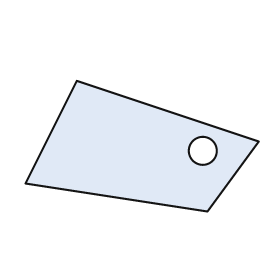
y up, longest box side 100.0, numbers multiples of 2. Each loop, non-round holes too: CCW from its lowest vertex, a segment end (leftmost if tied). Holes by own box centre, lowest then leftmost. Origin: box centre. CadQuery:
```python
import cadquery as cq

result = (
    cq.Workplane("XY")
    .moveTo(28.0, -28.0)
    .lineTo(50.0, 2.0)
    .lineTo(-28.0, 28.0)
    .lineTo(-50.0, -16.0)
    .close()
    .moveTo(26.0, -2.0)
    .circle(6.0)
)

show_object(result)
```